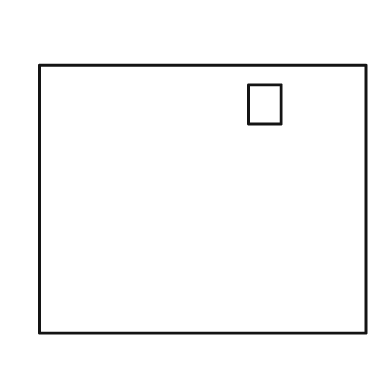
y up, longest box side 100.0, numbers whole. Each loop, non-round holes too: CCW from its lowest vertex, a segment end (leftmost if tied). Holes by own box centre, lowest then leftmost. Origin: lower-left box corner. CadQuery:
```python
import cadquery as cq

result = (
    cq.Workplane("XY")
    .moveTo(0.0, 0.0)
    .lineTo(100.0, 0.0)
    .lineTo(100.0, 82.0)
    .lineTo(0.0, 82.0)
    .close()
    .moveTo(64.0, 64.0)
    .lineTo(74.0, 64.0)
    .lineTo(74.0, 76.0)
    .lineTo(64.0, 76.0)
    .close()
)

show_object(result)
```